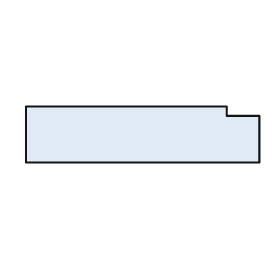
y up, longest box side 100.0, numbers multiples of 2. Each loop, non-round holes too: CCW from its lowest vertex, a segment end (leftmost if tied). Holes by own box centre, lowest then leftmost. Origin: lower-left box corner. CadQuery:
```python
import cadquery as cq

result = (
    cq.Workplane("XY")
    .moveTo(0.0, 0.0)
    .lineTo(100.0, 0.0)
    .lineTo(100.0, 20.0)
    .lineTo(86.0, 20.0)
    .lineTo(86.0, 24.0)
    .lineTo(0.0, 24.0)
    .close()
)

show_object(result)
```